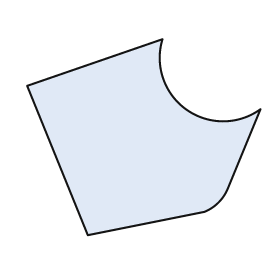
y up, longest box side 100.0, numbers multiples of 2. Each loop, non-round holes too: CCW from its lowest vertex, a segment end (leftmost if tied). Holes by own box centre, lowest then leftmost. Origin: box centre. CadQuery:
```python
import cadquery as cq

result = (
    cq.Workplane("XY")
    .moveTo(-24.0, -42.0)
    .lineTo(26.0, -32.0)
    .threePointArc((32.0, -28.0), (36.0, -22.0))
    .lineTo(50.0, 12.0)
    .threePointArc((18.0, 12.0), (8.0, 42.0))
    .lineTo(-50.0, 22.0)
    .close()
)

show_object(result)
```